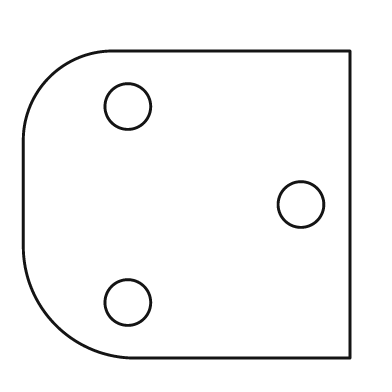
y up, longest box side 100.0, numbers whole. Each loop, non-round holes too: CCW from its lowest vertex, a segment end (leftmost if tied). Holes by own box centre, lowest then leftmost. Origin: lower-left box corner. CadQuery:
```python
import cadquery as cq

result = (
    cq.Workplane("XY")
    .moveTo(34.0, 0.0)
    .lineTo(100.0, 0.0)
    .lineTo(100.0, 94.0)
    .lineTo(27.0, 94.0)
    .threePointArc((8.0, 86.0), (0.0, 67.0))
    .lineTo(0.0, 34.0)
    .threePointArc((10.0, 10.0), (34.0, 0.0))
    .close()
    .moveTo(32.0, 17.0)
    .circle(7.0)
    .moveTo(85.0, 47.0)
    .circle(7.0)
    .moveTo(32.0, 77.0)
    .circle(7.0)
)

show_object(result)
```